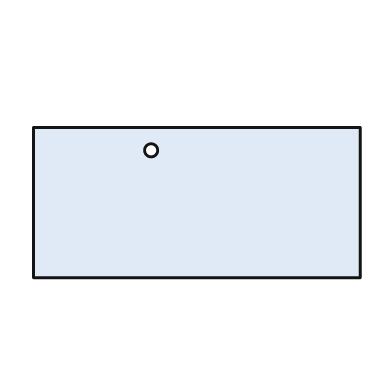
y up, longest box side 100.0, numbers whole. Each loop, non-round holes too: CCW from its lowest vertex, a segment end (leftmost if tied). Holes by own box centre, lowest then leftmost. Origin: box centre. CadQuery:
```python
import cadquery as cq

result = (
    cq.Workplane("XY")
    .moveTo(-50.0, -23.0)
    .lineTo(50.0, -23.0)
    .lineTo(50.0, 23.0)
    .lineTo(-50.0, 23.0)
    .close()
    .moveTo(-14.0, 16.0)
    .circle(2.0)
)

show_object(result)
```